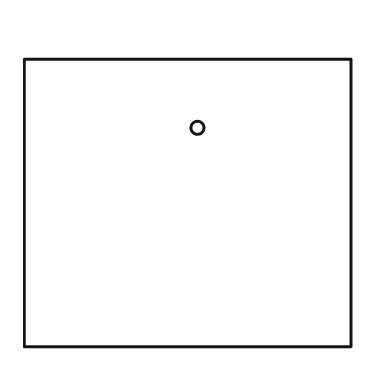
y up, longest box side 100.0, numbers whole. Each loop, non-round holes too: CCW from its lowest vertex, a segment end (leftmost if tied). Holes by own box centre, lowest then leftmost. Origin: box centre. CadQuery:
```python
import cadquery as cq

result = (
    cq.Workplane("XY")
    .moveTo(-50.0, -44.0)
    .lineTo(50.0, -44.0)
    .lineTo(50.0, 44.0)
    .lineTo(-50.0, 44.0)
    .close()
    .moveTo(3.0, 23.0)
    .circle(2.0)
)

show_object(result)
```